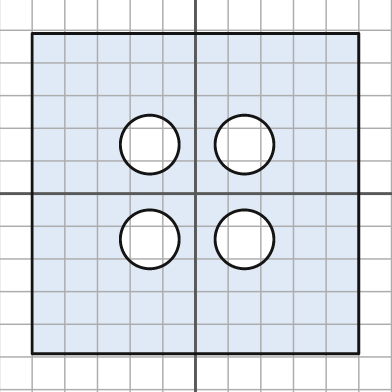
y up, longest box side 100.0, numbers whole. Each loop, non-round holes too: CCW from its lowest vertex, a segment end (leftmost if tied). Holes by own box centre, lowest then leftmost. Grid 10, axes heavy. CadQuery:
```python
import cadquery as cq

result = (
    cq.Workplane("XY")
    .moveTo(-50.0, -49.0)
    .lineTo(50.0, -49.0)
    .lineTo(50.0, 49.0)
    .lineTo(-50.0, 49.0)
    .close()
    .moveTo(-14.0, -14.0)
    .circle(9.0)
    .moveTo(15.0, -14.0)
    .circle(9.0)
    .moveTo(-14.0, 15.0)
    .circle(9.0)
    .moveTo(15.0, 15.0)
    .circle(9.0)
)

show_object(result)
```